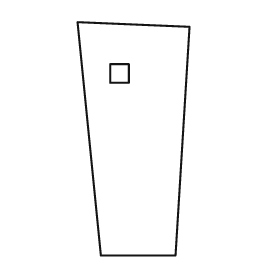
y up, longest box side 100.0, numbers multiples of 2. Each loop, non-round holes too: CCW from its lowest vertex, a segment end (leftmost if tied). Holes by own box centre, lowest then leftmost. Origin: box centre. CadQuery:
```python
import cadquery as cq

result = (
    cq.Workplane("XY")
    .moveTo(-14.0, -50.0)
    .lineTo(18.0, -50.0)
    .lineTo(24.0, 48.0)
    .lineTo(-24.0, 50.0)
    .close()
    .moveTo(-10.0, 24.0)
    .lineTo(-2.0, 24.0)
    .lineTo(-2.0, 32.0)
    .lineTo(-10.0, 32.0)
    .close()
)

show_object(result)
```